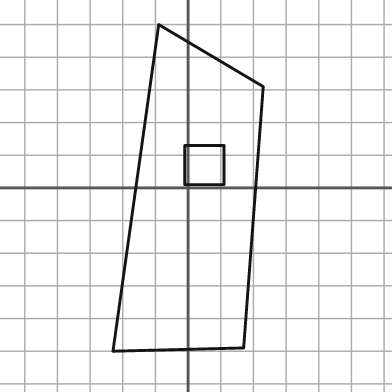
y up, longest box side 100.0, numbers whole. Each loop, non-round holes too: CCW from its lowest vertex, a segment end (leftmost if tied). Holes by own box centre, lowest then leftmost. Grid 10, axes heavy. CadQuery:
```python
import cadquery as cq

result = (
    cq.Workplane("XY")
    .moveTo(-23.0, -50.0)
    .lineTo(17.0, -49.0)
    .lineTo(23.0, 31.0)
    .lineTo(-9.0, 50.0)
    .close()
    .moveTo(-1.0, 1.0)
    .lineTo(11.0, 1.0)
    .lineTo(11.0, 13.0)
    .lineTo(-1.0, 13.0)
    .close()
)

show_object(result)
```